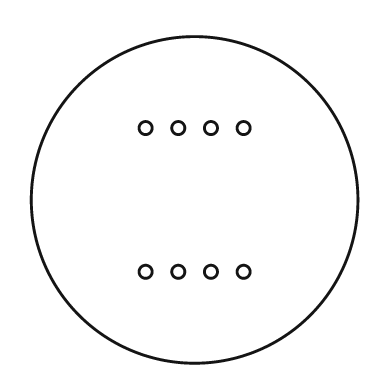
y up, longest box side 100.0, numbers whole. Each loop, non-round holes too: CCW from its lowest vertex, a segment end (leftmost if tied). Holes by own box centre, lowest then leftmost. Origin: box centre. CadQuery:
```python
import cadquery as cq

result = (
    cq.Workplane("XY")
    .moveTo(0.0, 0.0)
    .circle(50.0)
    .moveTo(-15.0, -22.0)
    .circle(2.0)
    .moveTo(-5.0, -22.0)
    .circle(2.0)
    .moveTo(5.0, -22.0)
    .circle(2.0)
    .moveTo(15.0, -22.0)
    .circle(2.0)
    .moveTo(-15.0, 22.0)
    .circle(2.0)
    .moveTo(-5.0, 22.0)
    .circle(2.0)
    .moveTo(5.0, 22.0)
    .circle(2.0)
    .moveTo(15.0, 22.0)
    .circle(2.0)
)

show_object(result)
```